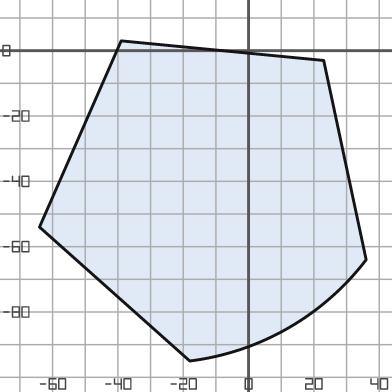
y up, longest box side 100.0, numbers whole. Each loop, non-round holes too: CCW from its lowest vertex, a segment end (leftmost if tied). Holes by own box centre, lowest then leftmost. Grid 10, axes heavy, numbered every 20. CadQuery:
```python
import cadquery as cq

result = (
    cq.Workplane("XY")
    .moveTo(-18.0, -95.0)
    .threePointArc((12.0, -85.0), (36.0, -64.0))
    .lineTo(23.0, -3.0)
    .lineTo(-39.0, 3.0)
    .lineTo(-64.0, -54.0)
    .close()
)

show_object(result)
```